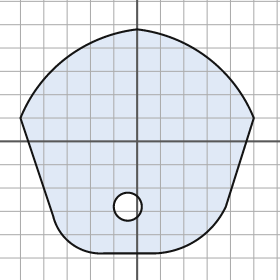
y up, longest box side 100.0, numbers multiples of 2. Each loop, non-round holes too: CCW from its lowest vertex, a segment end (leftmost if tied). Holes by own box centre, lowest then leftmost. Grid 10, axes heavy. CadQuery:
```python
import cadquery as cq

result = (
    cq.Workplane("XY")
    .moveTo(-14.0, -48.0)
    .lineTo(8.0, -48.0)
    .threePointArc((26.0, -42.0), (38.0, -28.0))
    .lineTo(50.0, 10.0)
    .threePointArc((30.0, 36.0), (0.0, 48.0))
    .threePointArc((-30.0, 36.0), (-50.0, 10.0))
    .lineTo(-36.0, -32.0)
    .threePointArc((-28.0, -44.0), (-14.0, -48.0))
    .close()
    .moveTo(-4.0, -28.0)
    .circle(6.0)
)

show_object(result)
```